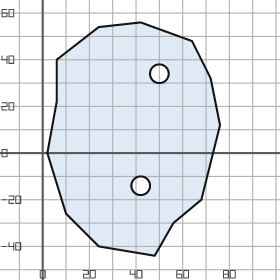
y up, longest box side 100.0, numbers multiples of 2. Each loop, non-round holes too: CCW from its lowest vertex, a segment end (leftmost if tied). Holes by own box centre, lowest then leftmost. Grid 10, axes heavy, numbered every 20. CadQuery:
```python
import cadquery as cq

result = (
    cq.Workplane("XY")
    .moveTo(48.0, -44.0)
    .lineTo(56.0, -30.0)
    .lineTo(68.0, -20.0)
    .lineTo(76.0, 12.0)
    .lineTo(72.0, 32.0)
    .lineTo(64.0, 48.0)
    .lineTo(42.0, 56.0)
    .lineTo(24.0, 54.0)
    .lineTo(6.0, 40.0)
    .lineTo(6.0, 22.0)
    .lineTo(2.0, 0.0)
    .lineTo(10.0, -26.0)
    .lineTo(24.0, -40.0)
    .close()
    .moveTo(42.0, -14.0)
    .circle(4.0)
    .moveTo(50.0, 34.0)
    .circle(4.0)
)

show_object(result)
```